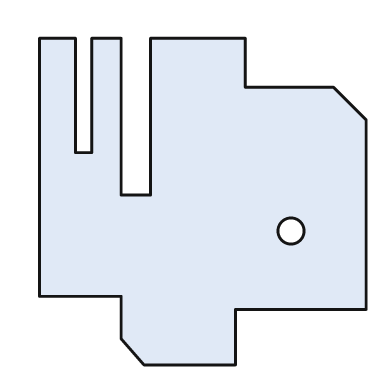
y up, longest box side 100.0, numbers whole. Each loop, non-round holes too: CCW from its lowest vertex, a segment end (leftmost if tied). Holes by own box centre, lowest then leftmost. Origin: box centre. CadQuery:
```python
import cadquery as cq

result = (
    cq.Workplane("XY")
    .moveTo(-18.0, -50.0)
    .lineTo(10.0, -50.0)
    .lineTo(10.0, -33.0)
    .lineTo(50.0, -33.0)
    .lineTo(50.0, 25.0)
    .lineTo(40.0, 35.0)
    .lineTo(13.0, 35.0)
    .lineTo(13.0, 50.0)
    .lineTo(-16.0, 50.0)
    .lineTo(-16.0, 2.0)
    .lineTo(-25.0, 2.0)
    .lineTo(-25.0, 50.0)
    .lineTo(-34.0, 50.0)
    .lineTo(-34.0, 15.0)
    .lineTo(-39.0, 15.0)
    .lineTo(-39.0, 50.0)
    .lineTo(-50.0, 50.0)
    .lineTo(-50.0, -29.0)
    .lineTo(-25.0, -29.0)
    .lineTo(-25.0, -42.0)
    .close()
    .moveTo(27.0, -9.0)
    .circle(4.0)
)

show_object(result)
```